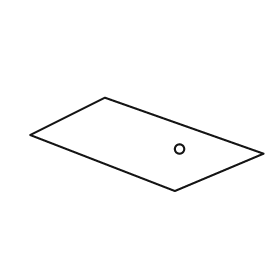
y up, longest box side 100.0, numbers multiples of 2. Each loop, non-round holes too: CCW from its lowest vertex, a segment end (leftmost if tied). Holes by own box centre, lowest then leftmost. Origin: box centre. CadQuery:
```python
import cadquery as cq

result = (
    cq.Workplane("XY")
    .moveTo(12.0, -20.0)
    .lineTo(50.0, -4.0)
    .lineTo(-18.0, 20.0)
    .lineTo(-50.0, 4.0)
    .close()
    .moveTo(14.0, -2.0)
    .circle(2.0)
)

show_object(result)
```